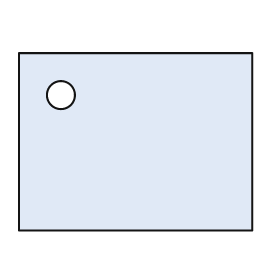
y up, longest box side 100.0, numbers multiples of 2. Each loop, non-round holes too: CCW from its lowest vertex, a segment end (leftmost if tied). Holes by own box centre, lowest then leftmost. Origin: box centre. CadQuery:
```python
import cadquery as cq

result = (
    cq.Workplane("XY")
    .moveTo(-50.0, -38.0)
    .lineTo(50.0, -38.0)
    .lineTo(50.0, 38.0)
    .lineTo(-50.0, 38.0)
    .close()
    .moveTo(-32.0, 20.0)
    .circle(6.0)
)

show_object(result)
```